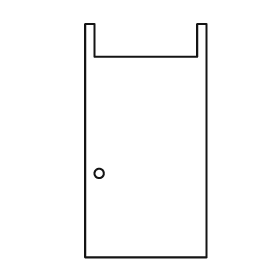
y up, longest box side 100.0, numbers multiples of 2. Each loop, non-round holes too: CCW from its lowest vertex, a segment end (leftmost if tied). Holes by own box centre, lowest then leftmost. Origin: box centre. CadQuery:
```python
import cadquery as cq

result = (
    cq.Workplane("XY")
    .moveTo(-26.0, -50.0)
    .lineTo(26.0, -50.0)
    .lineTo(26.0, 50.0)
    .lineTo(22.0, 50.0)
    .lineTo(22.0, 36.0)
    .lineTo(-22.0, 36.0)
    .lineTo(-22.0, 50.0)
    .lineTo(-26.0, 50.0)
    .close()
    .moveTo(-20.0, -14.0)
    .circle(2.0)
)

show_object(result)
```